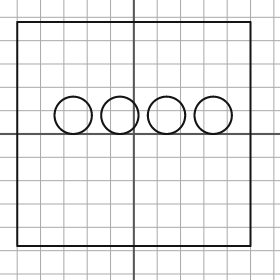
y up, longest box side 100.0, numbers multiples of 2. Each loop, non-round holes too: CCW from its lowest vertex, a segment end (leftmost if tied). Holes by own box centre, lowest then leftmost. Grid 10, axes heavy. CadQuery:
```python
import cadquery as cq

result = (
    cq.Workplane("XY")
    .moveTo(-50.0, -48.0)
    .lineTo(50.0, -48.0)
    .lineTo(50.0, 48.0)
    .lineTo(-50.0, 48.0)
    .close()
    .moveTo(-26.0, 8.0)
    .circle(8.0)
    .moveTo(-6.0, 8.0)
    .circle(8.0)
    .moveTo(14.0, 8.0)
    .circle(8.0)
    .moveTo(34.0, 8.0)
    .circle(8.0)
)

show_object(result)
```